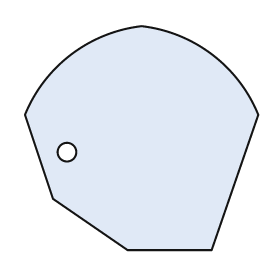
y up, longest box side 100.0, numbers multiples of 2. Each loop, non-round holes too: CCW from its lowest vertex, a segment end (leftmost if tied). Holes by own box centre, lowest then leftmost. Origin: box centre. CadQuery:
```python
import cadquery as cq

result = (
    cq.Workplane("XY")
    .moveTo(-6.0, -48.0)
    .lineTo(30.0, -48.0)
    .lineTo(50.0, 10.0)
    .threePointArc((30.0, 36.0), (0.0, 48.0))
    .threePointArc((-30.0, 36.0), (-50.0, 10.0))
    .lineTo(-38.0, -26.0)
    .close()
    .moveTo(-32.0, -6.0)
    .circle(4.0)
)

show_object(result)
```